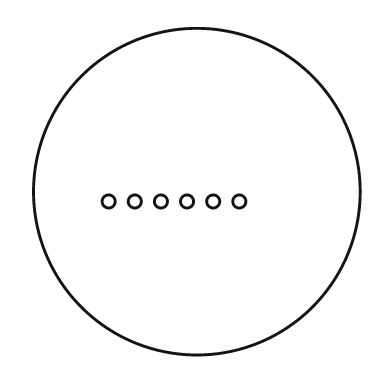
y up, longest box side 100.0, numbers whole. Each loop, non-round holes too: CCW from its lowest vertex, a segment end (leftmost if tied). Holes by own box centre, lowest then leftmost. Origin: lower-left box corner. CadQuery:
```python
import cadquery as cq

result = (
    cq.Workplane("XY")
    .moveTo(50.0, 50.0)
    .circle(50.0)
    .moveTo(23.0, 47.0)
    .circle(2.0)
    .moveTo(31.0, 47.0)
    .circle(2.0)
    .moveTo(39.0, 47.0)
    .circle(2.0)
    .moveTo(47.0, 47.0)
    .circle(2.0)
    .moveTo(55.0, 47.0)
    .circle(2.0)
    .moveTo(63.0, 47.0)
    .circle(2.0)
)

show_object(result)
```